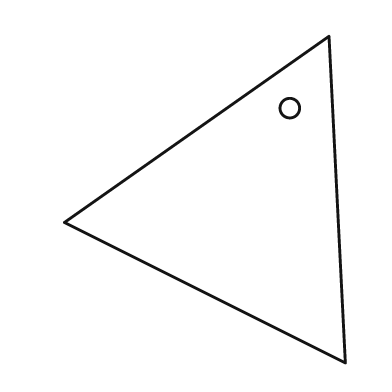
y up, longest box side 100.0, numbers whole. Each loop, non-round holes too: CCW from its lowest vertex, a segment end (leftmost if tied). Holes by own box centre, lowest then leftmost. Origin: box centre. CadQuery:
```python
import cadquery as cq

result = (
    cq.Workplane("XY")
    .moveTo(43.0, -50.0)
    .lineTo(38.0, 50.0)
    .lineTo(-43.0, -7.0)
    .close()
    .moveTo(26.0, 28.0)
    .circle(3.0)
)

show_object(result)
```